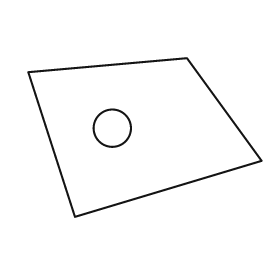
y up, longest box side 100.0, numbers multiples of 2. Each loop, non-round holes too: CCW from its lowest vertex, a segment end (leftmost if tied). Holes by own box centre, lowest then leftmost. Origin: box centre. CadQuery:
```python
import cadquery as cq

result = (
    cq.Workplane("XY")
    .moveTo(-30.0, -34.0)
    .lineTo(50.0, -10.0)
    .lineTo(18.0, 34.0)
    .lineTo(-50.0, 28.0)
    .close()
    .moveTo(-14.0, 4.0)
    .circle(8.0)
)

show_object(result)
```